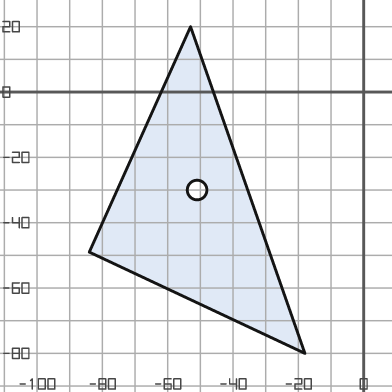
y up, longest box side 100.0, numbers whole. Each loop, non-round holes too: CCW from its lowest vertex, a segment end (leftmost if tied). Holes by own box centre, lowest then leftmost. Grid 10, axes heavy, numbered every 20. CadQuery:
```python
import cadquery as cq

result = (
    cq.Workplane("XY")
    .moveTo(-18.0, -80.0)
    .lineTo(-53.0, 20.0)
    .lineTo(-84.0, -49.0)
    .close()
    .moveTo(-51.0, -30.0)
    .circle(3.0)
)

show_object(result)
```